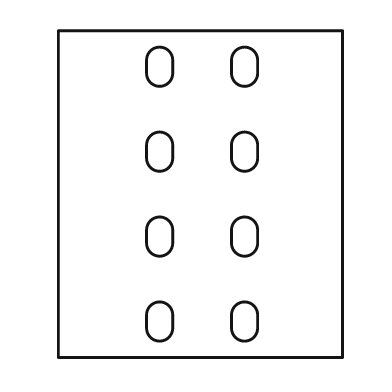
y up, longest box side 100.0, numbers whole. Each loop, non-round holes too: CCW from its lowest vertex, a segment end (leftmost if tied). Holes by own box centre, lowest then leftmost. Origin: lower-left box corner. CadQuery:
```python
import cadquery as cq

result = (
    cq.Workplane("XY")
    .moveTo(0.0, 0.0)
    .lineTo(87.0, 0.0)
    .lineTo(87.0, 100.0)
    .lineTo(0.0, 100.0)
    .close()
    .moveTo(27.0, 9.0)
    .threePointArc((31.0, 5.0), (35.0, 9.0))
    .lineTo(35.0, 13.0)
    .threePointArc((31.0, 17.0), (27.0, 13.0))
    .close()
    .moveTo(53.0, 9.0)
    .threePointArc((57.0, 5.0), (61.0, 9.0))
    .lineTo(61.0, 13.0)
    .threePointArc((57.0, 17.0), (53.0, 13.0))
    .close()
    .moveTo(27.0, 35.0)
    .threePointArc((31.0, 31.0), (35.0, 35.0))
    .lineTo(35.0, 39.0)
    .threePointArc((31.0, 43.0), (27.0, 39.0))
    .close()
    .moveTo(53.0, 35.0)
    .threePointArc((57.0, 31.0), (61.0, 35.0))
    .lineTo(61.0, 39.0)
    .threePointArc((57.0, 43.0), (53.0, 39.0))
    .close()
    .moveTo(27.0, 61.0)
    .threePointArc((31.0, 57.0), (35.0, 61.0))
    .lineTo(35.0, 65.0)
    .threePointArc((31.0, 69.0), (27.0, 65.0))
    .close()
    .moveTo(53.0, 61.0)
    .threePointArc((57.0, 57.0), (61.0, 61.0))
    .lineTo(61.0, 65.0)
    .threePointArc((57.0, 69.0), (53.0, 65.0))
    .close()
    .moveTo(27.0, 87.0)
    .threePointArc((31.0, 83.0), (35.0, 87.0))
    .lineTo(35.0, 91.0)
    .threePointArc((31.0, 95.0), (27.0, 91.0))
    .close()
    .moveTo(53.0, 87.0)
    .threePointArc((57.0, 83.0), (61.0, 87.0))
    .lineTo(61.0, 91.0)
    .threePointArc((57.0, 95.0), (53.0, 91.0))
    .close()
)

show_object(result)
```